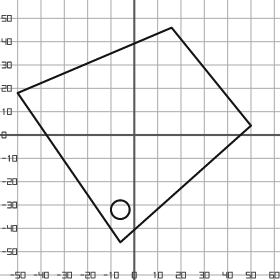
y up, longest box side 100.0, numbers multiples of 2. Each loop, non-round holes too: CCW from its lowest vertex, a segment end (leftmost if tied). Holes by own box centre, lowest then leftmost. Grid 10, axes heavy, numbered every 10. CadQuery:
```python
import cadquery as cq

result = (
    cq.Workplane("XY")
    .moveTo(-6.0, -46.0)
    .lineTo(50.0, 4.0)
    .lineTo(16.0, 46.0)
    .lineTo(-50.0, 18.0)
    .close()
    .moveTo(-6.0, -32.0)
    .circle(4.0)
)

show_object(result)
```